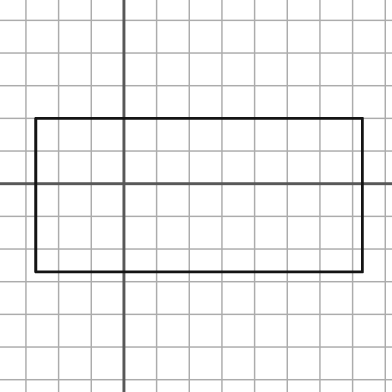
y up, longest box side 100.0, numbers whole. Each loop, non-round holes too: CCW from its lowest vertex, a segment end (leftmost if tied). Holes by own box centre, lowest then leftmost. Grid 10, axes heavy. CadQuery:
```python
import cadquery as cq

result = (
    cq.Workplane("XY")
    .moveTo(-27.0, -27.0)
    .lineTo(73.0, -27.0)
    .lineTo(73.0, 20.0)
    .lineTo(-27.0, 20.0)
    .close()
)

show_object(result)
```